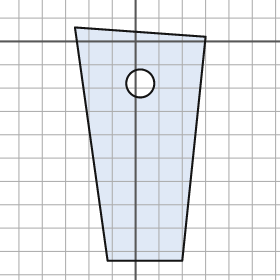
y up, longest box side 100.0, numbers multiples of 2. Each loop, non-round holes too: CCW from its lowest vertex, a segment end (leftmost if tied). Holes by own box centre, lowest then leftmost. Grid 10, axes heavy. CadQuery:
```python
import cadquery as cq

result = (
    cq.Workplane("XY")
    .moveTo(-12.0, -94.0)
    .lineTo(20.0, -94.0)
    .lineTo(30.0, 2.0)
    .lineTo(-26.0, 6.0)
    .close()
    .moveTo(2.0, -18.0)
    .circle(6.0)
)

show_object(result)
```